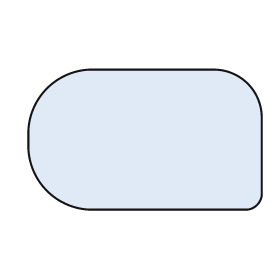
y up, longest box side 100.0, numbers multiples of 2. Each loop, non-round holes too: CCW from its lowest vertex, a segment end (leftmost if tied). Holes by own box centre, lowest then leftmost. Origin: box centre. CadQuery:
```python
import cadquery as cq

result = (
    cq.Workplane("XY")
    .moveTo(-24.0, -30.0)
    .lineTo(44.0, -30.0)
    .threePointArc((48.0, -28.0), (50.0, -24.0))
    .lineTo(50.0, 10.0)
    .threePointArc((44.0, 24.0), (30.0, 30.0))
    .lineTo(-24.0, 30.0)
    .threePointArc((-42.0, 22.0), (-50.0, 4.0))
    .lineTo(-50.0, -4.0)
    .threePointArc((-42.0, -22.0), (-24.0, -30.0))
    .close()
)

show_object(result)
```